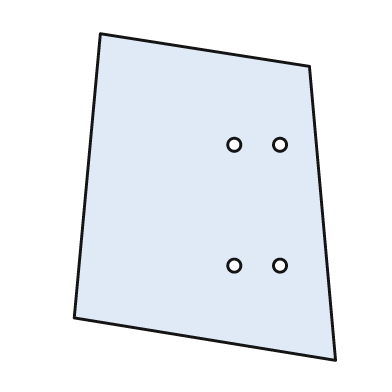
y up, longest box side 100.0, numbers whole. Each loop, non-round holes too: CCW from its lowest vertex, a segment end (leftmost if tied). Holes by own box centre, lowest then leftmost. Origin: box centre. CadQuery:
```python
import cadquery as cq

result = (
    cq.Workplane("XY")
    .moveTo(40.0, -50.0)
    .lineTo(32.0, 40.0)
    .lineTo(-32.0, 50.0)
    .lineTo(-40.0, -37.0)
    .close()
    .moveTo(9.0, -21.0)
    .circle(2.0)
    .moveTo(23.0, -21.0)
    .circle(2.0)
    .moveTo(9.0, 16.0)
    .circle(2.0)
    .moveTo(23.0, 16.0)
    .circle(2.0)
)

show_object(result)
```